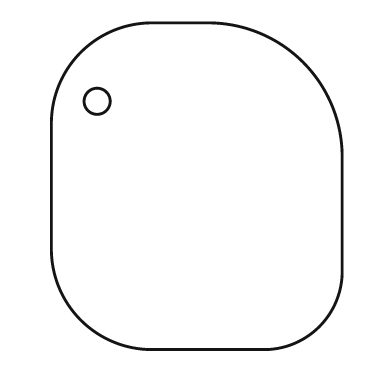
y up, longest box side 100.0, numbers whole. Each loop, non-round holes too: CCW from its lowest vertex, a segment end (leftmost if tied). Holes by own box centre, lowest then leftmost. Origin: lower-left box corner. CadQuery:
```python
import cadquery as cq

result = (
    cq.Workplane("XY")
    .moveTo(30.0, 0.0)
    .lineTo(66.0, 0.0)
    .threePointArc((82.0, 7.0), (89.0, 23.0))
    .lineTo(89.0, 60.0)
    .threePointArc((77.0, 88.0), (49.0, 100.0))
    .lineTo(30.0, 100.0)
    .threePointArc((9.0, 91.0), (0.0, 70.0))
    .lineTo(0.0, 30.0)
    .threePointArc((9.0, 9.0), (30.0, 0.0))
    .close()
    .moveTo(14.0, 76.0)
    .circle(4.0)
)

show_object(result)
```